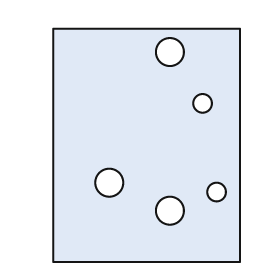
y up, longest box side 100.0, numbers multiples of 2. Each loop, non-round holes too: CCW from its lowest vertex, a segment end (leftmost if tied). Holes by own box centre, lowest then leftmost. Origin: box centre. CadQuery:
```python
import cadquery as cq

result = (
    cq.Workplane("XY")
    .moveTo(-40.0, -50.0)
    .lineTo(40.0, -50.0)
    .lineTo(40.0, 50.0)
    .lineTo(-40.0, 50.0)
    .close()
    .moveTo(10.0, -28.0)
    .circle(6.0)
    .moveTo(30.0, -20.0)
    .circle(4.0)
    .moveTo(-16.0, -16.0)
    .circle(6.0)
    .moveTo(24.0, 18.0)
    .circle(4.0)
    .moveTo(10.0, 40.0)
    .circle(6.0)
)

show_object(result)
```